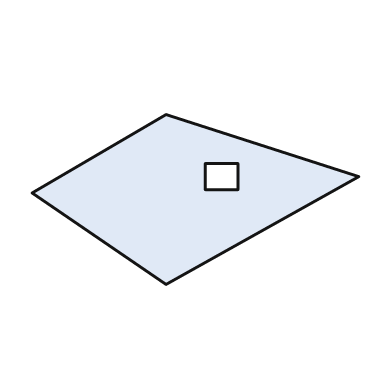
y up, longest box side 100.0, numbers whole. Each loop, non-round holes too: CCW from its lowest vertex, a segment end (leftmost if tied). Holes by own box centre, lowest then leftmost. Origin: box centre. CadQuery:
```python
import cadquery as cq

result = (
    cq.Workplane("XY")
    .moveTo(-9.0, -26.0)
    .lineTo(50.0, 7.0)
    .lineTo(-9.0, 26.0)
    .lineTo(-50.0, 2.0)
    .close()
    .moveTo(3.0, 3.0)
    .lineTo(13.0, 3.0)
    .lineTo(13.0, 11.0)
    .lineTo(3.0, 11.0)
    .close()
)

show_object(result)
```